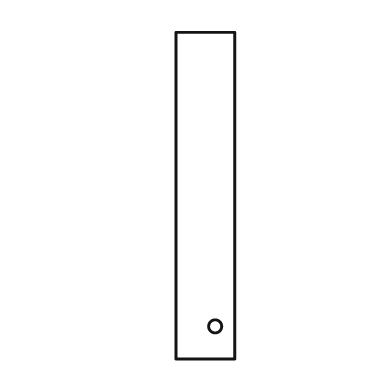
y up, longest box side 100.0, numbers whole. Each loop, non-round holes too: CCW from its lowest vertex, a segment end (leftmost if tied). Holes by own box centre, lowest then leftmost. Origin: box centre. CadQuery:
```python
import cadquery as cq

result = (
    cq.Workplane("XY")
    .moveTo(-9.0, -50.0)
    .lineTo(9.0, -50.0)
    .lineTo(9.0, 50.0)
    .lineTo(-9.0, 50.0)
    .close()
    .moveTo(3.0, -40.0)
    .circle(2.0)
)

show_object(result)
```